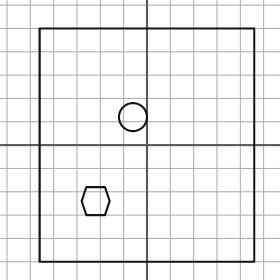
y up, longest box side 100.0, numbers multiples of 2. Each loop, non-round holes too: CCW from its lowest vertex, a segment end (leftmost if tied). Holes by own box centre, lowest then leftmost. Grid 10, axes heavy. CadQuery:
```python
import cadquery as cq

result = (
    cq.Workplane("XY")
    .moveTo(-46.0, -50.0)
    .lineTo(46.0, -50.0)
    .lineTo(46.0, 50.0)
    .lineTo(-46.0, 50.0)
    .close()
    .moveTo(-26.0, -30.0)
    .lineTo(-18.0, -30.0)
    .lineTo(-16.0, -24.0)
    .lineTo(-18.0, -18.0)
    .lineTo(-26.0, -18.0)
    .lineTo(-28.0, -24.0)
    .close()
    .moveTo(-6.0, 12.0)
    .circle(6.0)
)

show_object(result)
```